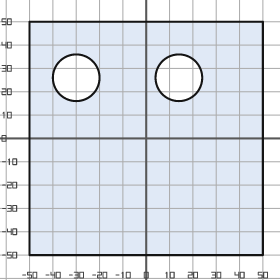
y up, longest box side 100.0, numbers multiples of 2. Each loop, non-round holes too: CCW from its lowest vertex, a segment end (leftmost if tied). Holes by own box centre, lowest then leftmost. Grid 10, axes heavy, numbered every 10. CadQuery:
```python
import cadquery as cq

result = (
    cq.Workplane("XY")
    .moveTo(-50.0, -50.0)
    .lineTo(50.0, -50.0)
    .lineTo(50.0, 50.0)
    .lineTo(-50.0, 50.0)
    .close()
    .moveTo(-30.0, 26.0)
    .circle(10.0)
    .moveTo(14.0, 26.0)
    .circle(10.0)
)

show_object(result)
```